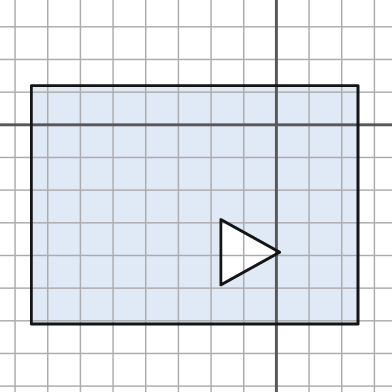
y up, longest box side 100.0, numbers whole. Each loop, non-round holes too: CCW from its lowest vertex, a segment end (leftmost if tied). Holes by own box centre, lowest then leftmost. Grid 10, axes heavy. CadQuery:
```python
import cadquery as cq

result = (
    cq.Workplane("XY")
    .moveTo(-75.0, -61.0)
    .lineTo(25.0, -61.0)
    .lineTo(25.0, 12.0)
    .lineTo(-75.0, 12.0)
    .close()
    .moveTo(-17.0, -49.0)
    .lineTo(1.0, -39.0)
    .lineTo(-17.0, -29.0)
    .close()
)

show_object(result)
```